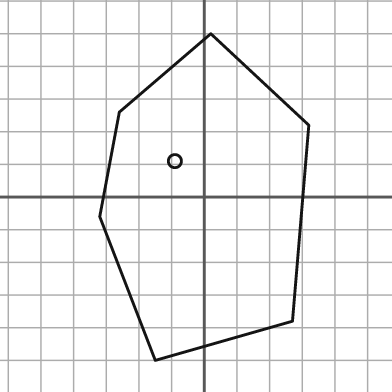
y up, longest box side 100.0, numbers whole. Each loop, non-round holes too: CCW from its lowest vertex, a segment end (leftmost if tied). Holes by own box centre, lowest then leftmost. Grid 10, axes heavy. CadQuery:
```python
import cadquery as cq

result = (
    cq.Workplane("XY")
    .moveTo(-15.0, -50.0)
    .lineTo(27.0, -38.0)
    .lineTo(32.0, 22.0)
    .lineTo(2.0, 50.0)
    .lineTo(-26.0, 26.0)
    .lineTo(-32.0, -6.0)
    .close()
    .moveTo(-9.0, 11.0)
    .circle(2.0)
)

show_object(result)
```